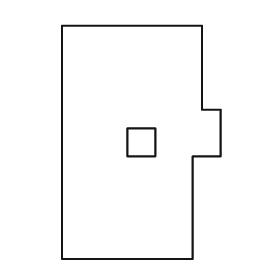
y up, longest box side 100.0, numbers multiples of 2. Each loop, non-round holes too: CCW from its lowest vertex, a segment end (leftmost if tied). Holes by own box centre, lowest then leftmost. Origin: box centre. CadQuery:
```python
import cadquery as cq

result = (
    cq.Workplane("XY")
    .moveTo(-34.0, -50.0)
    .lineTo(22.0, -50.0)
    .lineTo(22.0, -6.0)
    .lineTo(34.0, -6.0)
    .lineTo(34.0, 14.0)
    .lineTo(26.0, 14.0)
    .lineTo(26.0, 50.0)
    .lineTo(-34.0, 50.0)
    .close()
    .moveTo(-6.0, -6.0)
    .lineTo(6.0, -6.0)
    .lineTo(6.0, 6.0)
    .lineTo(-6.0, 6.0)
    .close()
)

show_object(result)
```